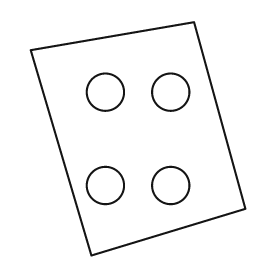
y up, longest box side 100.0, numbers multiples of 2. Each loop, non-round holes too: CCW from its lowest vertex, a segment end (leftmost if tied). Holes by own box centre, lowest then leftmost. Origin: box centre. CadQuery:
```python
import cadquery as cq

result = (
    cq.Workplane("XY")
    .moveTo(-20.0, -50.0)
    .lineTo(46.0, -30.0)
    .lineTo(24.0, 50.0)
    .lineTo(-46.0, 38.0)
    .close()
    .moveTo(-14.0, -20.0)
    .circle(8.0)
    .moveTo(14.0, -20.0)
    .circle(8.0)
    .moveTo(-14.0, 20.0)
    .circle(8.0)
    .moveTo(14.0, 20.0)
    .circle(8.0)
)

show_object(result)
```